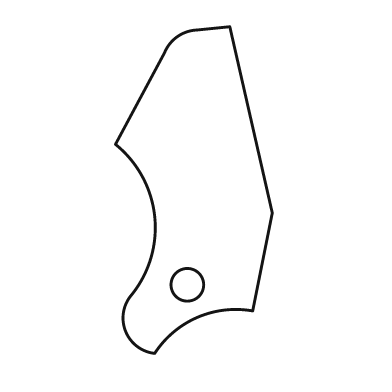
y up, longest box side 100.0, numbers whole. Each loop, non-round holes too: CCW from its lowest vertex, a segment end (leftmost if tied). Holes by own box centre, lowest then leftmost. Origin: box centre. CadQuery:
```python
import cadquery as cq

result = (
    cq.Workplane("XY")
    .moveTo(-12.0, -50.0)
    .threePointArc((1.0, -39.0), (18.0, -37.0))
    .lineTo(24.0, -7.0)
    .lineTo(11.0, 50.0)
    .lineTo(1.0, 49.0)
    .threePointArc((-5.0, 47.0), (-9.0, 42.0))
    .lineTo(-24.0, 14.0)
    .threePointArc((-12.0, -8.0), (-19.0, -32.0))
    .threePointArc((-21.0, -43.0), (-12.0, -50.0))
    .close()
    .moveTo(-2.0, -29.0)
    .circle(5.0)
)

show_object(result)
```